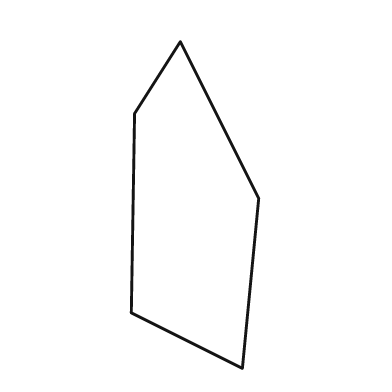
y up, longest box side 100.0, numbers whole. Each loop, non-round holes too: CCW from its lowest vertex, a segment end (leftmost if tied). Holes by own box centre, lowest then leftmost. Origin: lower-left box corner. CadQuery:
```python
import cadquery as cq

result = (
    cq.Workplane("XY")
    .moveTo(34.0, 0.0)
    .lineTo(39.0, 52.0)
    .lineTo(15.0, 100.0)
    .lineTo(1.0, 78.0)
    .lineTo(0.0, 17.0)
    .close()
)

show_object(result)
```